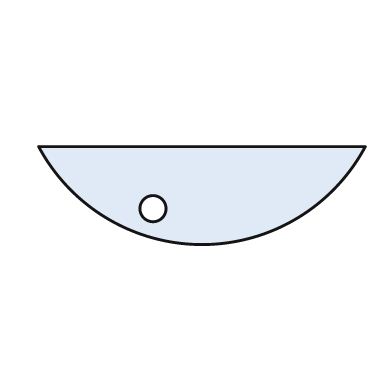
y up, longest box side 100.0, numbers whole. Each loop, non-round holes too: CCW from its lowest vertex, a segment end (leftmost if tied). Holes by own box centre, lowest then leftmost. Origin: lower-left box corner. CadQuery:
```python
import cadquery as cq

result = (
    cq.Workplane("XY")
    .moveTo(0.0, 30.0)
    .threePointArc((50.0, 0.0), (100.0, 30.0))
    .close()
    .moveTo(35.0, 11.0)
    .circle(4.0)
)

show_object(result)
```